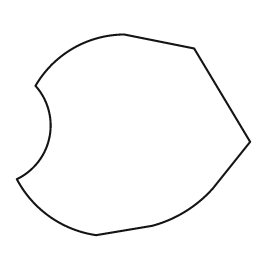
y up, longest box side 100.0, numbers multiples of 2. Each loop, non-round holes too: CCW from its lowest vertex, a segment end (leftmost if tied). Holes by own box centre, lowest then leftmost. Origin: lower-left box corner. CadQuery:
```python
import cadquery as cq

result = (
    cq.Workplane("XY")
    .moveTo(34.0, 0.0)
    .lineTo(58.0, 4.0)
    .threePointArc((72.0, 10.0), (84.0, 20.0))
    .lineTo(100.0, 40.0)
    .lineTo(76.0, 80.0)
    .lineTo(46.0, 86.0)
    .threePointArc((24.0, 80.0), (8.0, 64.0))
    .threePointArc((14.0, 42.0), (0.0, 24.0))
    .threePointArc((14.0, 8.0), (34.0, 0.0))
    .close()
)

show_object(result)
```